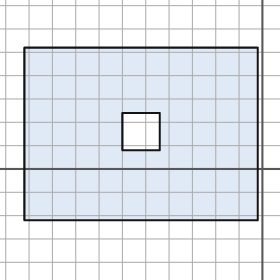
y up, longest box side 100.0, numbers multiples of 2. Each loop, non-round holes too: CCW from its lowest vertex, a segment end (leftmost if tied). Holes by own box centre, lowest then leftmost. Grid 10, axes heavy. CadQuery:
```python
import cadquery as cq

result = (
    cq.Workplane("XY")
    .moveTo(-102.0, -22.0)
    .lineTo(-2.0, -22.0)
    .lineTo(-2.0, 52.0)
    .lineTo(-102.0, 52.0)
    .close()
    .moveTo(-60.0, 8.0)
    .lineTo(-44.0, 8.0)
    .lineTo(-44.0, 24.0)
    .lineTo(-60.0, 24.0)
    .close()
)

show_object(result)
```